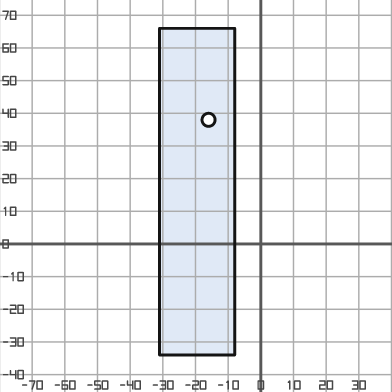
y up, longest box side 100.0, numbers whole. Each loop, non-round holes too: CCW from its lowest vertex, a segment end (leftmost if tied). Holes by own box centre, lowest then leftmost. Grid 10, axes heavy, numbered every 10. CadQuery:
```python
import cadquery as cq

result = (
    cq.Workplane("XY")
    .moveTo(-31.0, -34.0)
    .lineTo(-8.0, -34.0)
    .lineTo(-8.0, 66.0)
    .lineTo(-31.0, 66.0)
    .close()
    .moveTo(-16.0, 38.0)
    .circle(2.0)
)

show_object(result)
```